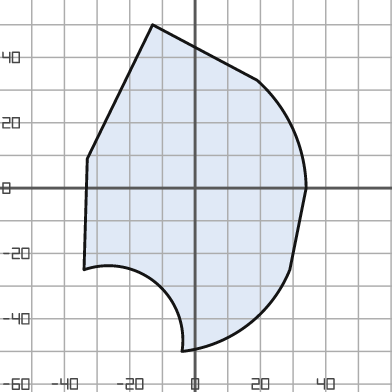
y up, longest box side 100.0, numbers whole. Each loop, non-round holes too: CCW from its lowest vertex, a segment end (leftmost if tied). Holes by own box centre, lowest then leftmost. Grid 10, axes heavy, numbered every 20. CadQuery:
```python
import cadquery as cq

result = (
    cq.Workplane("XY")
    .moveTo(-4.0, -50.0)
    .threePointArc((16.0, -42.0), (29.0, -25.0))
    .lineTo(34.0, 0.0)
    .threePointArc((30.0, 18.0), (19.0, 33.0))
    .lineTo(-13.0, 50.0)
    .lineTo(-33.0, 9.0)
    .lineTo(-34.0, -25.0)
    .threePointArc((-12.0, -29.0), (-4.0, -50.0))
    .close()
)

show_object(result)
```